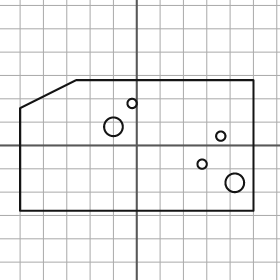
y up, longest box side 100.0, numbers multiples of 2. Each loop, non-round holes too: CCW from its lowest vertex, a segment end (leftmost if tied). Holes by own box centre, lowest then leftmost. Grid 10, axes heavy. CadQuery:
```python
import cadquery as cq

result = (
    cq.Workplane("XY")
    .moveTo(-50.0, -28.0)
    .lineTo(50.0, -28.0)
    .lineTo(50.0, 28.0)
    .lineTo(-26.0, 28.0)
    .lineTo(-50.0, 16.0)
    .close()
    .moveTo(42.0, -16.0)
    .circle(4.0)
    .moveTo(28.0, -8.0)
    .circle(2.0)
    .moveTo(36.0, 4.0)
    .circle(2.0)
    .moveTo(-10.0, 8.0)
    .circle(4.0)
    .moveTo(-2.0, 18.0)
    .circle(2.0)
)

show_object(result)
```